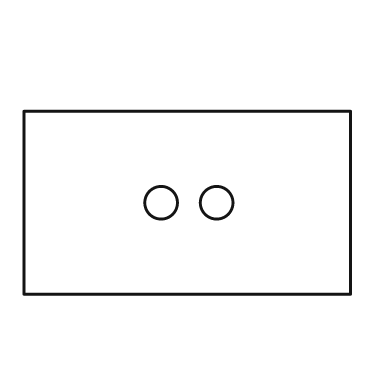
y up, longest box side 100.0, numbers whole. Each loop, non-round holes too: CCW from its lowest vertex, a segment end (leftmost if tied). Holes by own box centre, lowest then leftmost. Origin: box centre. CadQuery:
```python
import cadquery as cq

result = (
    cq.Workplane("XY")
    .moveTo(-50.0, -28.0)
    .lineTo(50.0, -28.0)
    .lineTo(50.0, 28.0)
    .lineTo(-50.0, 28.0)
    .close()
    .moveTo(-8.0, 0.0)
    .circle(5.0)
    .moveTo(9.0, 0.0)
    .circle(5.0)
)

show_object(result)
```